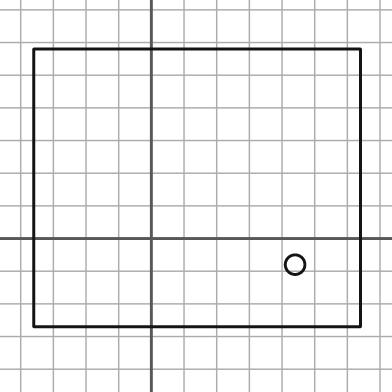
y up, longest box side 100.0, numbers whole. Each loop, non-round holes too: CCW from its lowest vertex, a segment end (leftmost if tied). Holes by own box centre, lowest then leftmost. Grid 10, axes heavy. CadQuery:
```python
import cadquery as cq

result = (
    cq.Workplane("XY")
    .moveTo(-36.0, -27.0)
    .lineTo(64.0, -27.0)
    .lineTo(64.0, 58.0)
    .lineTo(-36.0, 58.0)
    .close()
    .moveTo(44.0, -8.0)
    .circle(3.0)
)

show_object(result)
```